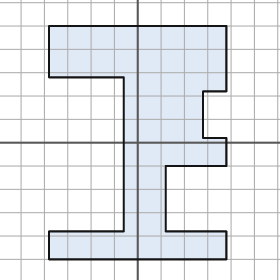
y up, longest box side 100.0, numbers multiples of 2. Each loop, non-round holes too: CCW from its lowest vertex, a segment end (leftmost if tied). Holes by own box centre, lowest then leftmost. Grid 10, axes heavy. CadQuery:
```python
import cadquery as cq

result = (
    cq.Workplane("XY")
    .moveTo(-38.0, -50.0)
    .lineTo(38.0, -50.0)
    .lineTo(38.0, -38.0)
    .lineTo(12.0, -38.0)
    .lineTo(12.0, -10.0)
    .lineTo(38.0, -10.0)
    .lineTo(38.0, 2.0)
    .lineTo(28.0, 2.0)
    .lineTo(28.0, 22.0)
    .lineTo(38.0, 22.0)
    .lineTo(38.0, 50.0)
    .lineTo(-38.0, 50.0)
    .lineTo(-38.0, 28.0)
    .lineTo(-6.0, 28.0)
    .lineTo(-6.0, -38.0)
    .lineTo(-38.0, -38.0)
    .close()
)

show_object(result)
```